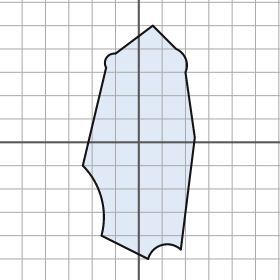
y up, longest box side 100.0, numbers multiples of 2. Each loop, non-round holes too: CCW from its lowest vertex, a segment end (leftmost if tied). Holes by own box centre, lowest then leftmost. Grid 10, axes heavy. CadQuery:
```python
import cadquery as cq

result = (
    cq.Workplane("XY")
    .moveTo(4.0, -50.0)
    .threePointArc((10.0, -44.0), (18.0, -46.0))
    .lineTo(24.0, 2.0)
    .lineTo(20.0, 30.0)
    .threePointArc((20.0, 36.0), (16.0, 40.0))
    .lineTo(6.0, 50.0)
    .lineTo(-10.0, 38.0)
    .threePointArc((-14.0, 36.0), (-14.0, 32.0))
    .lineTo(-24.0, -10.0)
    .threePointArc((-16.0, -24.0), (-16.0, -40.0))
    .close()
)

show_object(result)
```